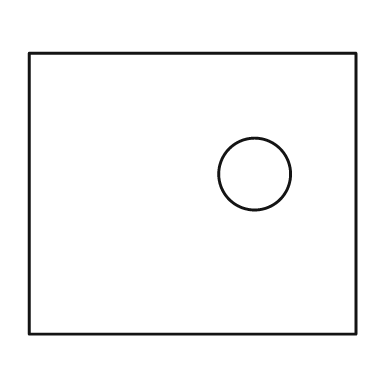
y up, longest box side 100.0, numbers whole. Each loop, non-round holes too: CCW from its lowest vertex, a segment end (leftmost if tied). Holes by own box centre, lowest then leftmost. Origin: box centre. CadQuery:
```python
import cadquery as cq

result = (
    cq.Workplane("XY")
    .moveTo(-50.0, -43.0)
    .lineTo(50.0, -43.0)
    .lineTo(50.0, 43.0)
    .lineTo(-50.0, 43.0)
    .close()
    .moveTo(19.0, 6.0)
    .circle(11.0)
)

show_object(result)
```